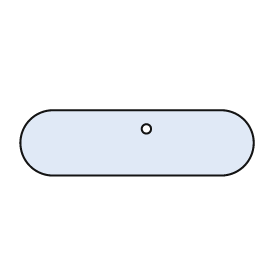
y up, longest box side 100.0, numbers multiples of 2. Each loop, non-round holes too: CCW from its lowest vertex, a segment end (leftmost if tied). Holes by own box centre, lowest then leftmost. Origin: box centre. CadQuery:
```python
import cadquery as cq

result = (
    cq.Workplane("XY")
    .moveTo(-36.0, -14.0)
    .lineTo(36.0, -14.0)
    .threePointArc((50.0, 0.0), (36.0, 14.0))
    .lineTo(-36.0, 14.0)
    .threePointArc((-50.0, 0.0), (-36.0, -14.0))
    .close()
    .moveTo(4.0, 6.0)
    .circle(2.0)
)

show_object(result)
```